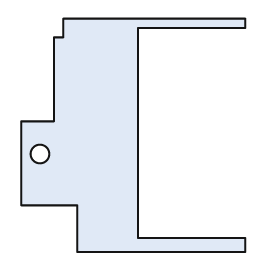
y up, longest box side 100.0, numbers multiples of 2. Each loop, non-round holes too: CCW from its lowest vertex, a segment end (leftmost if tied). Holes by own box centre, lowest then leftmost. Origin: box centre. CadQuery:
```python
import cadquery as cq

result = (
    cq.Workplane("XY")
    .moveTo(-24.0, -50.0)
    .lineTo(48.0, -50.0)
    .lineTo(48.0, -44.0)
    .lineTo(2.0, -44.0)
    .lineTo(2.0, 46.0)
    .lineTo(48.0, 46.0)
    .lineTo(48.0, 50.0)
    .lineTo(-30.0, 50.0)
    .lineTo(-30.0, 42.0)
    .lineTo(-34.0, 42.0)
    .lineTo(-34.0, 6.0)
    .lineTo(-48.0, 6.0)
    .lineTo(-48.0, -30.0)
    .lineTo(-24.0, -30.0)
    .close()
    .moveTo(-40.0, -8.0)
    .circle(4.0)
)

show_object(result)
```